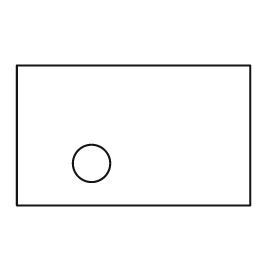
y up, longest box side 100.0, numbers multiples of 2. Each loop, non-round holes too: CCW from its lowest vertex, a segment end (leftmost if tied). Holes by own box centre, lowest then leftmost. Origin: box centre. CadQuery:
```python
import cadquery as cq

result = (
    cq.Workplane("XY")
    .moveTo(-50.0, -30.0)
    .lineTo(50.0, -30.0)
    .lineTo(50.0, 30.0)
    .lineTo(-50.0, 30.0)
    .close()
    .moveTo(-18.0, -12.0)
    .circle(8.0)
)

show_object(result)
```